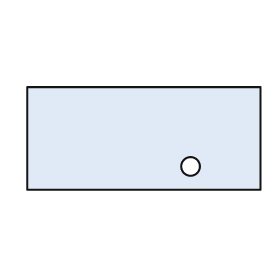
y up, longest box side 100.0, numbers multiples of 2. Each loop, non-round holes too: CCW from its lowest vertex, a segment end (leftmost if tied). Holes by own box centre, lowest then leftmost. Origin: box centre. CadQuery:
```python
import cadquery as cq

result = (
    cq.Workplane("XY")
    .moveTo(-50.0, -22.0)
    .lineTo(50.0, -22.0)
    .lineTo(50.0, 22.0)
    .lineTo(-50.0, 22.0)
    .close()
    .moveTo(20.0, -12.0)
    .circle(4.0)
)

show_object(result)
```